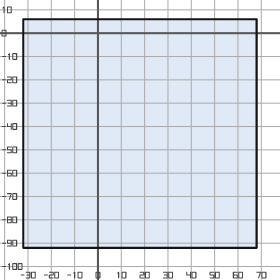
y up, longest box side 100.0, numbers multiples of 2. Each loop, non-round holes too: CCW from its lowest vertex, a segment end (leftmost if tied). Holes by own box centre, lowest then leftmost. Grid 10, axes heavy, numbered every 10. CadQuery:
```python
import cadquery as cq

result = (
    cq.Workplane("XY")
    .moveTo(-32.0, -92.0)
    .lineTo(68.0, -92.0)
    .lineTo(68.0, 6.0)
    .lineTo(-32.0, 6.0)
    .close()
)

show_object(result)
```